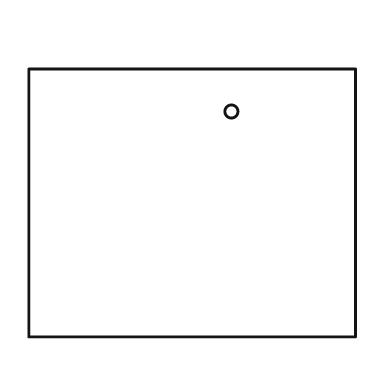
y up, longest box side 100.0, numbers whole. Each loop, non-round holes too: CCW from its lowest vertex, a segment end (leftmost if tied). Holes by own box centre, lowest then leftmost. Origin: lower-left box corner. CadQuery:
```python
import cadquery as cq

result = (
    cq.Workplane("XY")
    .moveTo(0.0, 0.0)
    .lineTo(100.0, 0.0)
    .lineTo(100.0, 82.0)
    .lineTo(0.0, 82.0)
    .close()
    .moveTo(62.0, 69.0)
    .circle(2.0)
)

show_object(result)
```